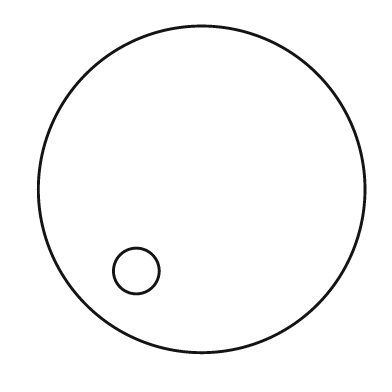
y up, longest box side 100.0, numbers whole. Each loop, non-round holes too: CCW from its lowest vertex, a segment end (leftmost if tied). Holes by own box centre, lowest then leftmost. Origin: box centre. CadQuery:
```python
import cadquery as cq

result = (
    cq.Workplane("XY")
    .moveTo(0.0, 0.0)
    .circle(50.0)
    .moveTo(-20.0, -25.0)
    .circle(7.0)
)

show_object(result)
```